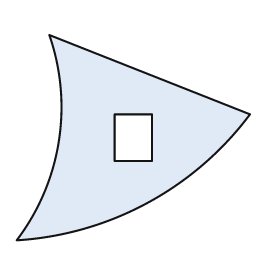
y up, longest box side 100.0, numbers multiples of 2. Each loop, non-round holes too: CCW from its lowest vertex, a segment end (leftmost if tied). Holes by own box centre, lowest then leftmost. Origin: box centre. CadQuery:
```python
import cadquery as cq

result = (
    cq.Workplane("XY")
    .moveTo(-50.0, -44.0)
    .threePointArc((6.0, -28.0), (50.0, 10.0))
    .lineTo(-36.0, 44.0)
    .threePointArc((-32.0, -2.0), (-50.0, -44.0))
    .close()
    .moveTo(-8.0, -10.0)
    .lineTo(8.0, -10.0)
    .lineTo(8.0, 10.0)
    .lineTo(-8.0, 10.0)
    .close()
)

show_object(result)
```